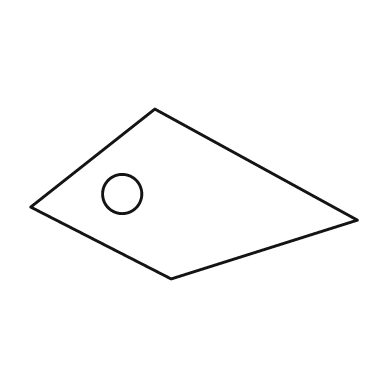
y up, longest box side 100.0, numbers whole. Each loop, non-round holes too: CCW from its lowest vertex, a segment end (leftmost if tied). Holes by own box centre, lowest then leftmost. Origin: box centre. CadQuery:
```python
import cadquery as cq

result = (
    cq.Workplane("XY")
    .moveTo(-7.0, -26.0)
    .lineTo(50.0, -8.0)
    .lineTo(-12.0, 26.0)
    .lineTo(-50.0, -4.0)
    .close()
    .moveTo(-22.0, 0.0)
    .circle(6.0)
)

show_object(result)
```